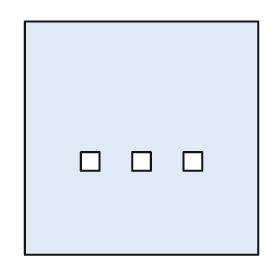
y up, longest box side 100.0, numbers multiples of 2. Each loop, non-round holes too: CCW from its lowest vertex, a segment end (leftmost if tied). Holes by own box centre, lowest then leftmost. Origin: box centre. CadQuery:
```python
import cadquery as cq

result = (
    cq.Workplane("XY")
    .moveTo(-50.0, -50.0)
    .lineTo(50.0, -50.0)
    .lineTo(50.0, 50.0)
    .lineTo(-50.0, 50.0)
    .close()
    .moveTo(-26.0, -14.0)
    .lineTo(-18.0, -14.0)
    .lineTo(-18.0, -6.0)
    .lineTo(-26.0, -6.0)
    .close()
    .moveTo(-4.0, -14.0)
    .lineTo(4.0, -14.0)
    .lineTo(4.0, -6.0)
    .lineTo(-4.0, -6.0)
    .close()
    .moveTo(18.0, -14.0)
    .lineTo(26.0, -14.0)
    .lineTo(26.0, -6.0)
    .lineTo(18.0, -6.0)
    .close()
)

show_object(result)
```